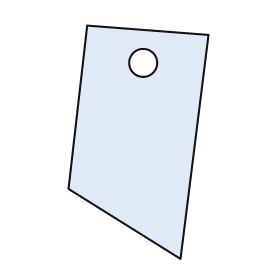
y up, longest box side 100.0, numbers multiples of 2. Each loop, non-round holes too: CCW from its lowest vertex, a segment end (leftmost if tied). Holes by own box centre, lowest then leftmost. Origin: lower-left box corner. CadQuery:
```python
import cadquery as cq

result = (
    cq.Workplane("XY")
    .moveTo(48.0, 0.0)
    .lineTo(60.0, 96.0)
    .lineTo(8.0, 100.0)
    .lineTo(0.0, 30.0)
    .close()
    .moveTo(32.0, 84.0)
    .circle(6.0)
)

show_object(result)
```